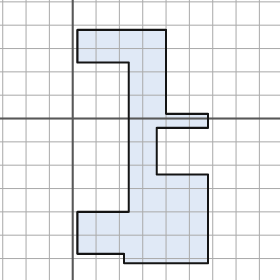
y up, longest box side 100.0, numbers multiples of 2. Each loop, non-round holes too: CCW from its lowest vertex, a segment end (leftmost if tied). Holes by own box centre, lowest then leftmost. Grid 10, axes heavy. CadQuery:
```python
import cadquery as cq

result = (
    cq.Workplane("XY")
    .moveTo(22.0, -62.0)
    .lineTo(58.0, -62.0)
    .lineTo(58.0, -24.0)
    .lineTo(36.0, -24.0)
    .lineTo(36.0, -4.0)
    .lineTo(58.0, -4.0)
    .lineTo(58.0, 2.0)
    .lineTo(40.0, 2.0)
    .lineTo(40.0, 38.0)
    .lineTo(2.0, 38.0)
    .lineTo(2.0, 24.0)
    .lineTo(24.0, 24.0)
    .lineTo(24.0, -40.0)
    .lineTo(2.0, -40.0)
    .lineTo(2.0, -58.0)
    .lineTo(22.0, -58.0)
    .close()
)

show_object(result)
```